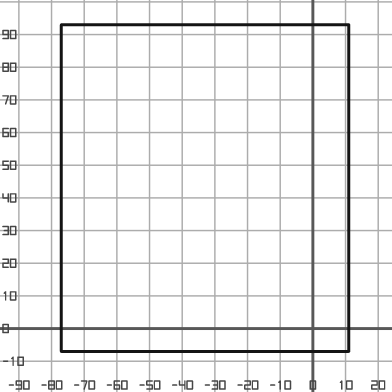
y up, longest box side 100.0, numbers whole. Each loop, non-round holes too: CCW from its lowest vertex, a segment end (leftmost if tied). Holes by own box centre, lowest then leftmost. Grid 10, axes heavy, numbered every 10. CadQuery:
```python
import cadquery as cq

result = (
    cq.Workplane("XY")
    .moveTo(-77.0, -7.0)
    .lineTo(11.0, -7.0)
    .lineTo(11.0, 93.0)
    .lineTo(-77.0, 93.0)
    .close()
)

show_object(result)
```